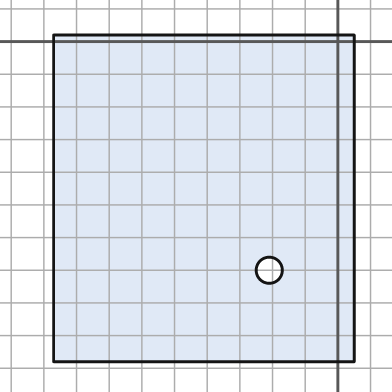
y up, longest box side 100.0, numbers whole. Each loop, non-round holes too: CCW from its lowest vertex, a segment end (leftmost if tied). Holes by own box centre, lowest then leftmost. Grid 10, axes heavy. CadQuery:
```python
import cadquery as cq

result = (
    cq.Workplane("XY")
    .moveTo(-87.0, -98.0)
    .lineTo(5.0, -98.0)
    .lineTo(5.0, 2.0)
    .lineTo(-87.0, 2.0)
    .close()
    .moveTo(-21.0, -70.0)
    .circle(4.0)
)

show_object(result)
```